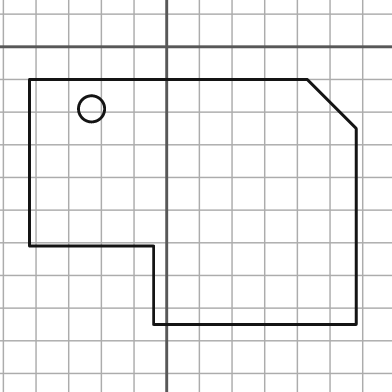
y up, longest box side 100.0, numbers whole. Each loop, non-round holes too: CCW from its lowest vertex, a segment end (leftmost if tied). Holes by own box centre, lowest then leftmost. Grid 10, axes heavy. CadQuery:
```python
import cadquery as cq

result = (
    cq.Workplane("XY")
    .moveTo(-4.0, -85.0)
    .lineTo(58.0, -85.0)
    .lineTo(58.0, -25.0)
    .lineTo(43.0, -10.0)
    .lineTo(-42.0, -10.0)
    .lineTo(-42.0, -61.0)
    .lineTo(-4.0, -61.0)
    .close()
    .moveTo(-23.0, -19.0)
    .circle(4.0)
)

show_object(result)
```